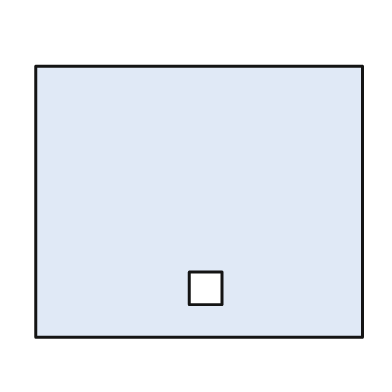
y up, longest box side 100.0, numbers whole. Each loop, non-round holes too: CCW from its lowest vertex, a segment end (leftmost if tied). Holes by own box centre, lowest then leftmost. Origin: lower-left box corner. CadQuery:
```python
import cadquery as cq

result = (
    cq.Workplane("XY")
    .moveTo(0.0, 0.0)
    .lineTo(100.0, 0.0)
    .lineTo(100.0, 83.0)
    .lineTo(0.0, 83.0)
    .close()
    .moveTo(47.0, 10.0)
    .lineTo(57.0, 10.0)
    .lineTo(57.0, 20.0)
    .lineTo(47.0, 20.0)
    .close()
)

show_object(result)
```